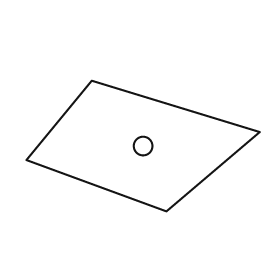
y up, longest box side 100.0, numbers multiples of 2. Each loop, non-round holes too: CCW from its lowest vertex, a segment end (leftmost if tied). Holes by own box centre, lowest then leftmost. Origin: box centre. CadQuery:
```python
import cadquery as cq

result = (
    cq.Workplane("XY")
    .moveTo(10.0, -28.0)
    .lineTo(50.0, 6.0)
    .lineTo(-22.0, 28.0)
    .lineTo(-50.0, -6.0)
    .close()
    .moveTo(0.0, 0.0)
    .circle(4.0)
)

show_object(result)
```